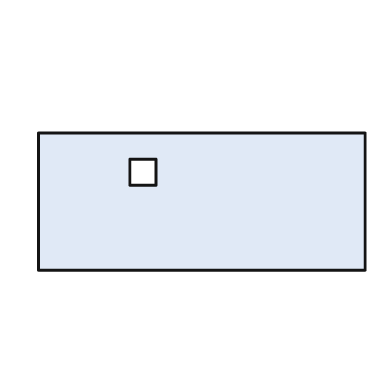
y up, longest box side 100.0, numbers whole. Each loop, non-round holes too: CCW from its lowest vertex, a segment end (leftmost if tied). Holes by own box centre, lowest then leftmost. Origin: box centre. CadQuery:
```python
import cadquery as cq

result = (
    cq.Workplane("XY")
    .moveTo(-50.0, -21.0)
    .lineTo(50.0, -21.0)
    .lineTo(50.0, 21.0)
    .lineTo(-50.0, 21.0)
    .close()
    .moveTo(-22.0, 5.0)
    .lineTo(-14.0, 5.0)
    .lineTo(-14.0, 13.0)
    .lineTo(-22.0, 13.0)
    .close()
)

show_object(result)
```